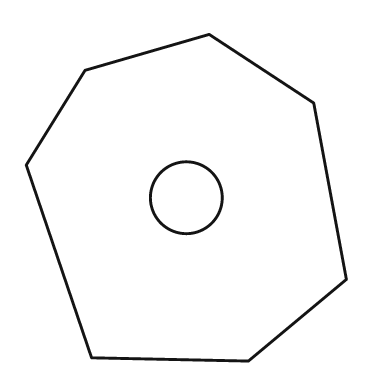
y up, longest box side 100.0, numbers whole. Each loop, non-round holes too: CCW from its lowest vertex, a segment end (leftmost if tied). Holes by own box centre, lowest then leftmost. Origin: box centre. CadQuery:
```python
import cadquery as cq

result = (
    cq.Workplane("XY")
    .moveTo(19.0, -50.0)
    .lineTo(49.0, -25.0)
    .lineTo(39.0, 29.0)
    .lineTo(7.0, 50.0)
    .lineTo(-31.0, 39.0)
    .lineTo(-49.0, 10.0)
    .lineTo(-29.0, -49.0)
    .close()
    .moveTo(0.0, 0.0)
    .circle(11.0)
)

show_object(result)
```